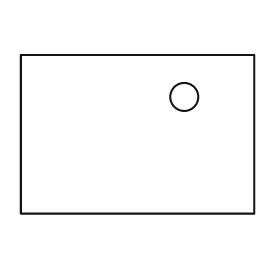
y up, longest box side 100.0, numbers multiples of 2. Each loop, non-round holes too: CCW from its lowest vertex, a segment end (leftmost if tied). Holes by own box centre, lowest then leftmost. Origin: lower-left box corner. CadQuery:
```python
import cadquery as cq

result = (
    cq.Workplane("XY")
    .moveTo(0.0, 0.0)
    .lineTo(100.0, 0.0)
    .lineTo(100.0, 68.0)
    .lineTo(0.0, 68.0)
    .close()
    .moveTo(70.0, 50.0)
    .circle(6.0)
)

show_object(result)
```